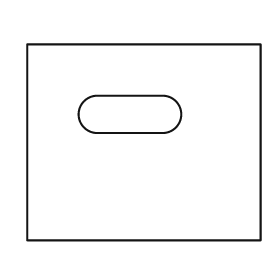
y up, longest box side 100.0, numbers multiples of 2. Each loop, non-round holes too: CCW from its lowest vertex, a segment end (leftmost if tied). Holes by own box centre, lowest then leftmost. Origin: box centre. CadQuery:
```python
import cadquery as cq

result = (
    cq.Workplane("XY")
    .moveTo(-50.0, -42.0)
    .lineTo(50.0, -42.0)
    .lineTo(50.0, 42.0)
    .lineTo(-50.0, 42.0)
    .close()
    .moveTo(-20.0, 4.0)
    .lineTo(8.0, 4.0)
    .threePointArc((16.0, 12.0), (8.0, 20.0))
    .lineTo(-20.0, 20.0)
    .threePointArc((-28.0, 12.0), (-20.0, 4.0))
    .close()
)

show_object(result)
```